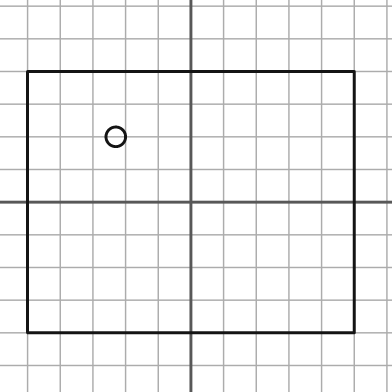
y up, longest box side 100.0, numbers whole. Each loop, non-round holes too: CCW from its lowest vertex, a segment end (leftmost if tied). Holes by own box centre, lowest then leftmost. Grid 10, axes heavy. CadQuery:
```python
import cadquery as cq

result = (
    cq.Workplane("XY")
    .moveTo(-50.0, -40.0)
    .lineTo(50.0, -40.0)
    .lineTo(50.0, 40.0)
    .lineTo(-50.0, 40.0)
    .close()
    .moveTo(-23.0, 20.0)
    .circle(3.0)
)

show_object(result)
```